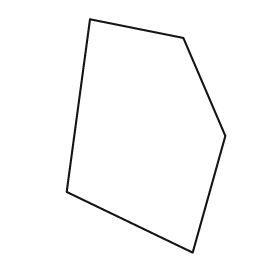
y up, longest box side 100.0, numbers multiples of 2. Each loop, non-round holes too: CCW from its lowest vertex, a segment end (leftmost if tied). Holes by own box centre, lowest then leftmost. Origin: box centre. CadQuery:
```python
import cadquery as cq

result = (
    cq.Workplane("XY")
    .moveTo(20.0, -50.0)
    .lineTo(34.0, 0.0)
    .lineTo(16.0, 42.0)
    .lineTo(-24.0, 50.0)
    .lineTo(-34.0, -24.0)
    .close()
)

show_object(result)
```